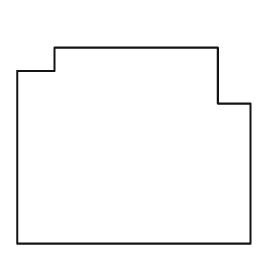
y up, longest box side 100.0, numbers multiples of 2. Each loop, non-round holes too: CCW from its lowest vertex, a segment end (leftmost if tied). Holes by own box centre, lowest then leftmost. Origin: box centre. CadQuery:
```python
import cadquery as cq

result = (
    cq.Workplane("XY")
    .moveTo(-50.0, -42.0)
    .lineTo(50.0, -42.0)
    .lineTo(50.0, 18.0)
    .lineTo(36.0, 18.0)
    .lineTo(36.0, 42.0)
    .lineTo(-34.0, 42.0)
    .lineTo(-34.0, 32.0)
    .lineTo(-50.0, 32.0)
    .close()
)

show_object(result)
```